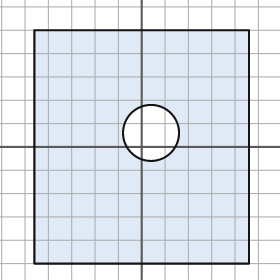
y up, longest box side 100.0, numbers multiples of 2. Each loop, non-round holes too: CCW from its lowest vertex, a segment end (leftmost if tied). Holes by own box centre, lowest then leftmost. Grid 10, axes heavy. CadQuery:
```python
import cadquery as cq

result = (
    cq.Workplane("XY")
    .moveTo(-46.0, -50.0)
    .lineTo(46.0, -50.0)
    .lineTo(46.0, 50.0)
    .lineTo(-46.0, 50.0)
    .close()
    .moveTo(4.0, 6.0)
    .circle(12.0)
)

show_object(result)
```